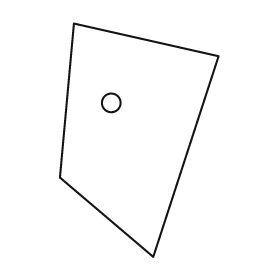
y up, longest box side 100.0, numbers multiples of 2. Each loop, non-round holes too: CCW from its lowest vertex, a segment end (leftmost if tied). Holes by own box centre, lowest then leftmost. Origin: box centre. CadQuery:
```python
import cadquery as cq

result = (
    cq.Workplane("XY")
    .moveTo(6.0, -50.0)
    .lineTo(34.0, 36.0)
    .lineTo(-28.0, 50.0)
    .lineTo(-34.0, -16.0)
    .close()
    .moveTo(-12.0, 16.0)
    .circle(4.0)
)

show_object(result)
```